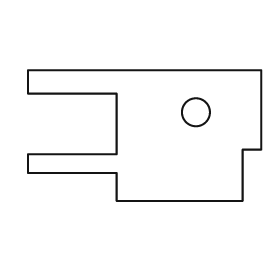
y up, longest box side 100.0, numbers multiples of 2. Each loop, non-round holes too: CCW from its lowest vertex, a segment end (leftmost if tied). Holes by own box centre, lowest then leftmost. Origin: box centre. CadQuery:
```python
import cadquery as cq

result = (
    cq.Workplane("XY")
    .moveTo(-12.0, -28.0)
    .lineTo(42.0, -28.0)
    .lineTo(42.0, -6.0)
    .lineTo(50.0, -6.0)
    .lineTo(50.0, 28.0)
    .lineTo(-50.0, 28.0)
    .lineTo(-50.0, 18.0)
    .lineTo(-12.0, 18.0)
    .lineTo(-12.0, -8.0)
    .lineTo(-50.0, -8.0)
    .lineTo(-50.0, -16.0)
    .lineTo(-12.0, -16.0)
    .close()
    .moveTo(22.0, 10.0)
    .circle(6.0)
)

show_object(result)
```